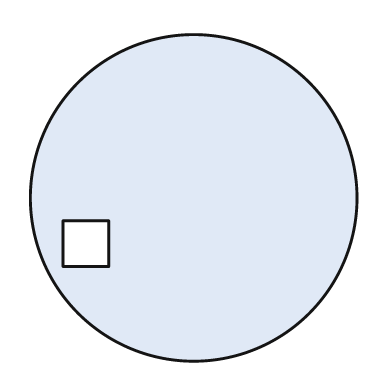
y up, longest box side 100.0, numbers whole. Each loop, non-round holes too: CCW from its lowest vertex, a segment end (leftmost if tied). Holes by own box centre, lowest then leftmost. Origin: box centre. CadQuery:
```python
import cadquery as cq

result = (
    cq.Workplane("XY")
    .moveTo(0.0, 0.0)
    .circle(50.0)
    .moveTo(-40.0, -21.0)
    .lineTo(-26.0, -21.0)
    .lineTo(-26.0, -7.0)
    .lineTo(-40.0, -7.0)
    .close()
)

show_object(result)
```